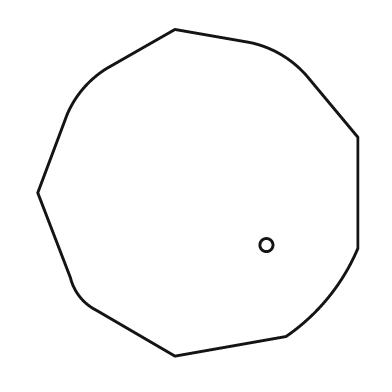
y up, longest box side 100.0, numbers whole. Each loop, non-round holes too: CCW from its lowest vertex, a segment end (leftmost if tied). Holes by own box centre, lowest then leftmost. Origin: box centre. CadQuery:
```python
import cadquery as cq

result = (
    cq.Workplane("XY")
    .moveTo(-7.0, -50.0)
    .lineTo(27.0, -44.0)
    .threePointArc((40.0, -32.0), (49.0, -17.0))
    .lineTo(49.0, 17.0)
    .lineTo(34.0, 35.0)
    .threePointArc((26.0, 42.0), (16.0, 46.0))
    .lineTo(-7.0, 50.0)
    .lineTo(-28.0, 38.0)
    .threePointArc((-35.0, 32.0), (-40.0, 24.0))
    .lineTo(-49.0, 0.0)
    .lineTo(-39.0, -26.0)
    .threePointArc((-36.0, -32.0), (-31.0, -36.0))
    .close()
    .moveTo(21.0, -16.0)
    .circle(2.0)
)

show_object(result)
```